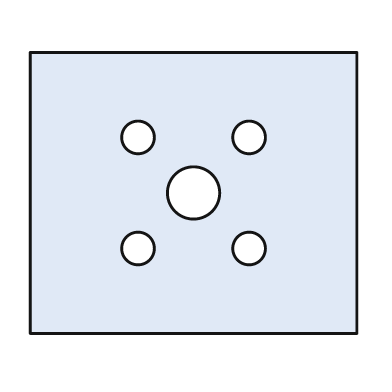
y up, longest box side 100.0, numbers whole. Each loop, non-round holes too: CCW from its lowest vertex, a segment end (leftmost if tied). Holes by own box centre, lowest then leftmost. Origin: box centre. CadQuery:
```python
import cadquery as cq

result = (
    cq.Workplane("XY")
    .moveTo(-50.0, -43.0)
    .lineTo(50.0, -43.0)
    .lineTo(50.0, 43.0)
    .lineTo(-50.0, 43.0)
    .close()
    .moveTo(-17.0, -17.0)
    .circle(5.0)
    .moveTo(17.0, -17.0)
    .circle(5.0)
    .moveTo(0.0, 0.0)
    .circle(8.0)
    .moveTo(-17.0, 17.0)
    .circle(5.0)
    .moveTo(17.0, 17.0)
    .circle(5.0)
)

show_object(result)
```